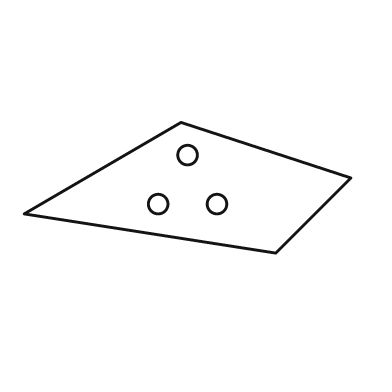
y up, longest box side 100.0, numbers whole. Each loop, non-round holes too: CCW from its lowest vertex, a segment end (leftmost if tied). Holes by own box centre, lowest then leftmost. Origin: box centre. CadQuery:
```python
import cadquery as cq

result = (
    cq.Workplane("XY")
    .moveTo(27.0, -20.0)
    .lineTo(50.0, 3.0)
    .lineTo(-2.0, 20.0)
    .lineTo(-50.0, -8.0)
    .close()
    .moveTo(-9.0, -5.0)
    .circle(3.0)
    .moveTo(9.0, -5.0)
    .circle(3.0)
    .moveTo(0.0, 10.0)
    .circle(3.0)
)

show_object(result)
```